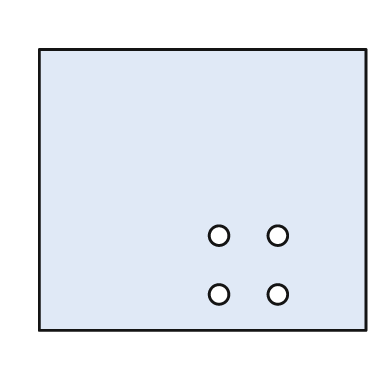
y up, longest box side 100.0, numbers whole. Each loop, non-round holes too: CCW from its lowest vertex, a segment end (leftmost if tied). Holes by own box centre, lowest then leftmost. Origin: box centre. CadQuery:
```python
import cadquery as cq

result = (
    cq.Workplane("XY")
    .moveTo(-50.0, -43.0)
    .lineTo(50.0, -43.0)
    .lineTo(50.0, 43.0)
    .lineTo(-50.0, 43.0)
    .close()
    .moveTo(5.0, -32.0)
    .circle(3.0)
    .moveTo(23.0, -32.0)
    .circle(3.0)
    .moveTo(5.0, -14.0)
    .circle(3.0)
    .moveTo(23.0, -14.0)
    .circle(3.0)
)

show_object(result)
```